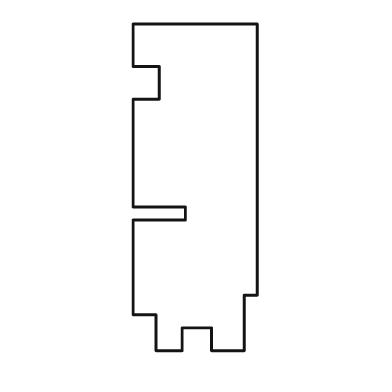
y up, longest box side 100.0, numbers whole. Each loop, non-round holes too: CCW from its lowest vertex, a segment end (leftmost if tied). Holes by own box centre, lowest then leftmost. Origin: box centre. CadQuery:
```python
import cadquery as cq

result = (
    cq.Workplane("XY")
    .moveTo(-12.0, -50.0)
    .lineTo(-4.0, -50.0)
    .lineTo(-4.0, -43.0)
    .lineTo(5.0, -43.0)
    .lineTo(5.0, -50.0)
    .lineTo(15.0, -50.0)
    .lineTo(15.0, -33.0)
    .lineTo(19.0, -33.0)
    .lineTo(19.0, 50.0)
    .lineTo(-19.0, 50.0)
    .lineTo(-19.0, 37.0)
    .lineTo(-11.0, 37.0)
    .lineTo(-11.0, 27.0)
    .lineTo(-19.0, 27.0)
    .lineTo(-19.0, -6.0)
    .lineTo(-3.0, -6.0)
    .lineTo(-3.0, -10.0)
    .lineTo(-19.0, -10.0)
    .lineTo(-19.0, -39.0)
    .lineTo(-12.0, -39.0)
    .close()
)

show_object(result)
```